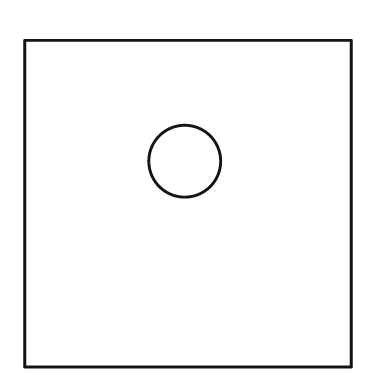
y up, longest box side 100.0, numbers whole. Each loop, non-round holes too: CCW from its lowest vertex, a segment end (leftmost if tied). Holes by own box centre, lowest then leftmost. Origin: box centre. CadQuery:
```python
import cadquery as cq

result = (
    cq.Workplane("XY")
    .moveTo(-50.0, -50.0)
    .lineTo(50.0, -50.0)
    .lineTo(50.0, 50.0)
    .lineTo(-50.0, 50.0)
    .close()
    .moveTo(-1.0, 13.0)
    .circle(11.0)
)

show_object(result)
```